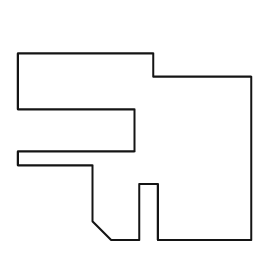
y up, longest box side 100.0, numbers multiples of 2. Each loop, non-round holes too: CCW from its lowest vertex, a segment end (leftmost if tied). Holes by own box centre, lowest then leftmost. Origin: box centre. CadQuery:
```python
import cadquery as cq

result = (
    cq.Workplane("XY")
    .moveTo(-10.0, -40.0)
    .lineTo(2.0, -40.0)
    .lineTo(2.0, -16.0)
    .lineTo(10.0, -16.0)
    .lineTo(10.0, -40.0)
    .lineTo(50.0, -40.0)
    .lineTo(50.0, 30.0)
    .lineTo(8.0, 30.0)
    .lineTo(8.0, 40.0)
    .lineTo(-50.0, 40.0)
    .lineTo(-50.0, 16.0)
    .lineTo(0.0, 16.0)
    .lineTo(0.0, -2.0)
    .lineTo(-50.0, -2.0)
    .lineTo(-50.0, -8.0)
    .lineTo(-18.0, -8.0)
    .lineTo(-18.0, -32.0)
    .close()
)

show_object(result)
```